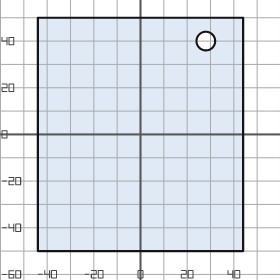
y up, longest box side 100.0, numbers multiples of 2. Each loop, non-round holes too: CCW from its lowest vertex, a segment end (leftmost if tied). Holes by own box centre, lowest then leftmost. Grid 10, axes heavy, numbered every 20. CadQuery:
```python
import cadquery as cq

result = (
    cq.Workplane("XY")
    .moveTo(-44.0, -50.0)
    .lineTo(44.0, -50.0)
    .lineTo(44.0, 50.0)
    .lineTo(-44.0, 50.0)
    .close()
    .moveTo(28.0, 40.0)
    .circle(4.0)
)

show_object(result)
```